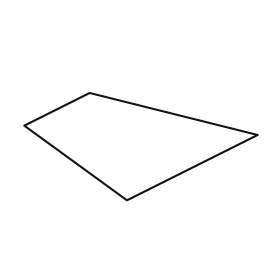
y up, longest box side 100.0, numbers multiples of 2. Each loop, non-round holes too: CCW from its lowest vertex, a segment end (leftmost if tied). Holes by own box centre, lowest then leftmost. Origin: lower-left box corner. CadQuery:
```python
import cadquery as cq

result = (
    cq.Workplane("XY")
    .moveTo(44.0, 0.0)
    .lineTo(100.0, 28.0)
    .lineTo(28.0, 46.0)
    .lineTo(0.0, 32.0)
    .close()
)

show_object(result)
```